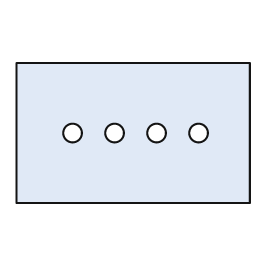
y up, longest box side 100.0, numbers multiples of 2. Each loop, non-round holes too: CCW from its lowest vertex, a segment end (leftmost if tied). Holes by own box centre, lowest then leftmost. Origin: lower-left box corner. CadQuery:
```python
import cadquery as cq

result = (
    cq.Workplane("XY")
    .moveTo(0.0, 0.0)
    .lineTo(100.0, 0.0)
    .lineTo(100.0, 60.0)
    .lineTo(0.0, 60.0)
    .close()
    .moveTo(24.0, 30.0)
    .circle(4.0)
    .moveTo(42.0, 30.0)
    .circle(4.0)
    .moveTo(60.0, 30.0)
    .circle(4.0)
    .moveTo(78.0, 30.0)
    .circle(4.0)
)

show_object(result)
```